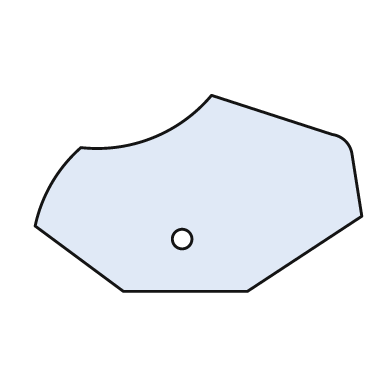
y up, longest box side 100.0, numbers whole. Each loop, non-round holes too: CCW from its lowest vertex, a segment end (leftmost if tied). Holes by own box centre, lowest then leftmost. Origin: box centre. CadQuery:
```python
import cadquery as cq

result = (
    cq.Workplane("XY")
    .moveTo(-23.0, -30.0)
    .lineTo(15.0, -30.0)
    .lineTo(50.0, -7.0)
    .lineTo(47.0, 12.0)
    .threePointArc((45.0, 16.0), (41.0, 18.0))
    .lineTo(4.0, 30.0)
    .threePointArc((-14.0, 17.0), (-36.0, 14.0))
    .threePointArc((-45.0, 3.0), (-50.0, -10.0))
    .close()
    .moveTo(-5.0, -14.0)
    .circle(3.0)
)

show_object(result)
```